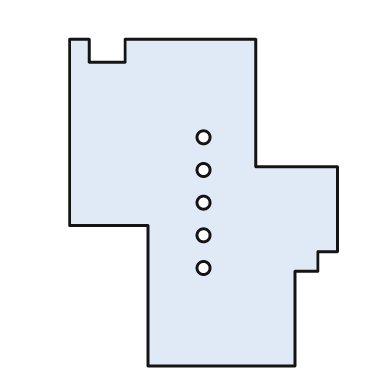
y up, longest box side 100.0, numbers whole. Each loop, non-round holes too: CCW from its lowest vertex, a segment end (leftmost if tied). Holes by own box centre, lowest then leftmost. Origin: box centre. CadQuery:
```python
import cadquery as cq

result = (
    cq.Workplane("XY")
    .moveTo(-17.0, -50.0)
    .lineTo(28.0, -50.0)
    .lineTo(28.0, -21.0)
    .lineTo(35.0, -21.0)
    .lineTo(35.0, -15.0)
    .lineTo(41.0, -15.0)
    .lineTo(41.0, 11.0)
    .lineTo(16.0, 11.0)
    .lineTo(16.0, 50.0)
    .lineTo(-24.0, 50.0)
    .lineTo(-24.0, 43.0)
    .lineTo(-35.0, 43.0)
    .lineTo(-35.0, 50.0)
    .lineTo(-41.0, 50.0)
    .lineTo(-41.0, -7.0)
    .lineTo(-17.0, -7.0)
    .close()
    .moveTo(0.0, -20.0)
    .circle(2.0)
    .moveTo(0.0, -10.0)
    .circle(2.0)
    .moveTo(0.0, 0.0)
    .circle(2.0)
    .moveTo(0.0, 10.0)
    .circle(2.0)
    .moveTo(0.0, 20.0)
    .circle(2.0)
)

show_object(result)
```